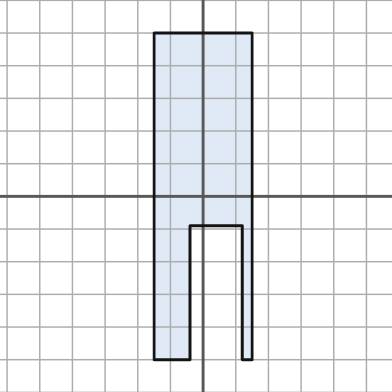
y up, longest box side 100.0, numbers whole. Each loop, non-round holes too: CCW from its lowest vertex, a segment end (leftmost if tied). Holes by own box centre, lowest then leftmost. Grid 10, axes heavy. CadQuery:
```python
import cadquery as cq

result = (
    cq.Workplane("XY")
    .moveTo(-15.0, -50.0)
    .lineTo(-4.0, -50.0)
    .lineTo(-4.0, -9.0)
    .lineTo(12.0, -9.0)
    .lineTo(12.0, -50.0)
    .lineTo(15.0, -50.0)
    .lineTo(15.0, 50.0)
    .lineTo(-15.0, 50.0)
    .close()
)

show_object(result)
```